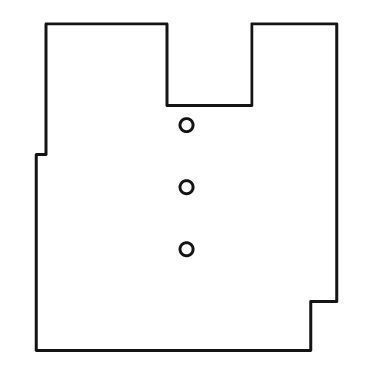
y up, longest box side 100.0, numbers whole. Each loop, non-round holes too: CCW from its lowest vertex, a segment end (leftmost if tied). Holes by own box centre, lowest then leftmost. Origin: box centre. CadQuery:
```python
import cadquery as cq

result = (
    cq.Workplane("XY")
    .moveTo(-46.0, -50.0)
    .lineTo(38.0, -50.0)
    .lineTo(38.0, -35.0)
    .lineTo(46.0, -35.0)
    .lineTo(46.0, 50.0)
    .lineTo(20.0, 50.0)
    .lineTo(20.0, 25.0)
    .lineTo(-6.0, 25.0)
    .lineTo(-6.0, 50.0)
    .lineTo(-43.0, 50.0)
    .lineTo(-43.0, 10.0)
    .lineTo(-46.0, 10.0)
    .close()
    .moveTo(0.0, -19.0)
    .circle(2.0)
    .moveTo(0.0, 0.0)
    .circle(2.0)
    .moveTo(0.0, 19.0)
    .circle(2.0)
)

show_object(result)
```